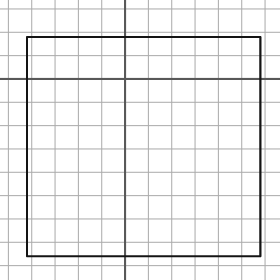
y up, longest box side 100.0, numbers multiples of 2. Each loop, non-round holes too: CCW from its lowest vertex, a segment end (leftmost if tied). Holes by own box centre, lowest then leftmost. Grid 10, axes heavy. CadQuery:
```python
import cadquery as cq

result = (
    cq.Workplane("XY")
    .moveTo(-42.0, -76.0)
    .lineTo(58.0, -76.0)
    .lineTo(58.0, 18.0)
    .lineTo(-42.0, 18.0)
    .close()
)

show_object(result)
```